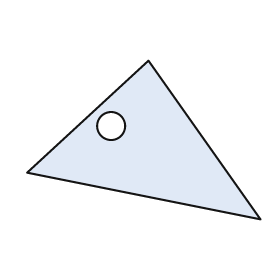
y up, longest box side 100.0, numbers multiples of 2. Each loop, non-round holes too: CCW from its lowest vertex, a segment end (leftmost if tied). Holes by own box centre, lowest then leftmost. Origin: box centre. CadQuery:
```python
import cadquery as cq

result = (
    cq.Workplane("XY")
    .moveTo(50.0, -34.0)
    .lineTo(2.0, 34.0)
    .lineTo(-50.0, -14.0)
    .close()
    .moveTo(-14.0, 6.0)
    .circle(6.0)
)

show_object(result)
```